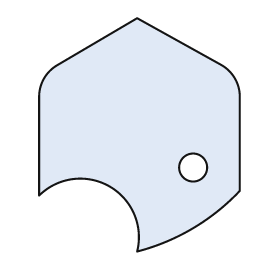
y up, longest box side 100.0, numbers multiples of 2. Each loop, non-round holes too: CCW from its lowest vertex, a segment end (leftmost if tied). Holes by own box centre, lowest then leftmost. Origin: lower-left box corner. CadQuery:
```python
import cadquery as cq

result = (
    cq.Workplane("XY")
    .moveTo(42.0, 0.0)
    .threePointArc((66.0, 10.0), (86.0, 26.0))
    .lineTo(86.0, 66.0)
    .threePointArc((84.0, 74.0), (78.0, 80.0))
    .lineTo(42.0, 100.0)
    .lineTo(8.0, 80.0)
    .threePointArc((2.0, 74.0), (0.0, 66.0))
    .lineTo(0.0, 24.0)
    .threePointArc((30.0, 28.0), (42.0, 0.0))
    .close()
    .moveTo(66.0, 36.0)
    .circle(6.0)
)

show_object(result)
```